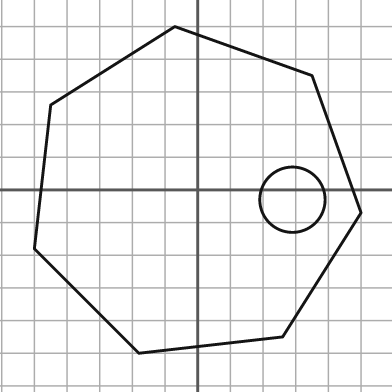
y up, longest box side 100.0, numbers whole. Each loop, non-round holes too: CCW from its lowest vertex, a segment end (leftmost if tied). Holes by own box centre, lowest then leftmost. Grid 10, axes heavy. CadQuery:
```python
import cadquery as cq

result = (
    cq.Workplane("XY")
    .moveTo(-18.0, -50.0)
    .lineTo(26.0, -45.0)
    .lineTo(50.0, -7.0)
    .lineTo(35.0, 35.0)
    .lineTo(-7.0, 50.0)
    .lineTo(-45.0, 26.0)
    .lineTo(-50.0, -18.0)
    .close()
    .moveTo(29.0, -3.0)
    .circle(10.0)
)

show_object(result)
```